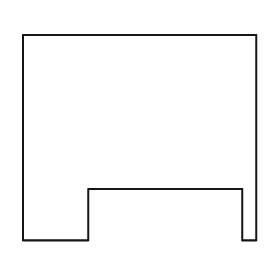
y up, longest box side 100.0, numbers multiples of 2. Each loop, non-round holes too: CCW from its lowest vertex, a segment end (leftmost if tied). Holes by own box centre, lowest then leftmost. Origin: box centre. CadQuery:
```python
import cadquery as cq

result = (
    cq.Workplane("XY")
    .moveTo(-50.0, -44.0)
    .lineTo(-22.0, -44.0)
    .lineTo(-22.0, -22.0)
    .lineTo(44.0, -22.0)
    .lineTo(44.0, -44.0)
    .lineTo(50.0, -44.0)
    .lineTo(50.0, 44.0)
    .lineTo(-50.0, 44.0)
    .close()
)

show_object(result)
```